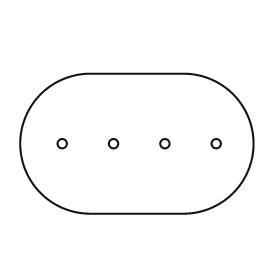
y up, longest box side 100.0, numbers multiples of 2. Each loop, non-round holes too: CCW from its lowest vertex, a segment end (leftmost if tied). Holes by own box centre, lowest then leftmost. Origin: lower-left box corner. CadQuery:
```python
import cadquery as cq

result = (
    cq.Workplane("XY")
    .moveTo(30.0, 0.0)
    .lineTo(70.0, 0.0)
    .threePointArc((100.0, 30.0), (70.0, 60.0))
    .lineTo(30.0, 60.0)
    .threePointArc((0.0, 30.0), (30.0, 0.0))
    .close()
    .moveTo(18.0, 30.0)
    .circle(2.0)
    .moveTo(40.0, 30.0)
    .circle(2.0)
    .moveTo(62.0, 30.0)
    .circle(2.0)
    .moveTo(84.0, 30.0)
    .circle(2.0)
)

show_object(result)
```